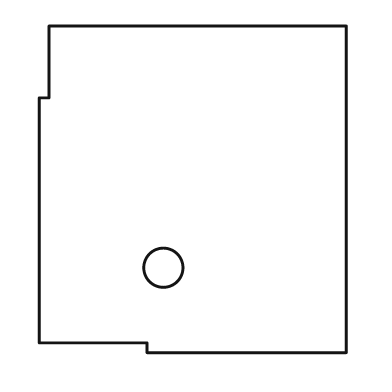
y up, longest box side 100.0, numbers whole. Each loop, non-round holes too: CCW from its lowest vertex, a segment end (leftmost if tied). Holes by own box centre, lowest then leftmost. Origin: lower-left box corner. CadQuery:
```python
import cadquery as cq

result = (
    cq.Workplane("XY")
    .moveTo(33.0, 0.0)
    .lineTo(94.0, 0.0)
    .lineTo(94.0, 100.0)
    .lineTo(3.0, 100.0)
    .lineTo(3.0, 78.0)
    .lineTo(0.0, 78.0)
    .lineTo(0.0, 3.0)
    .lineTo(33.0, 3.0)
    .close()
    .moveTo(38.0, 26.0)
    .circle(6.0)
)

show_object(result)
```